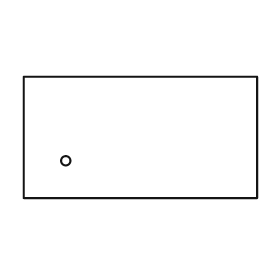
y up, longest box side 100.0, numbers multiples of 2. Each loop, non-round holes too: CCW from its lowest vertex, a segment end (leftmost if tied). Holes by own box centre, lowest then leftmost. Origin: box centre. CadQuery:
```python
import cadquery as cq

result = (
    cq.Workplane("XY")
    .moveTo(-50.0, -26.0)
    .lineTo(50.0, -26.0)
    .lineTo(50.0, 26.0)
    .lineTo(-50.0, 26.0)
    .close()
    .moveTo(-32.0, -10.0)
    .circle(2.0)
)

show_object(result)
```